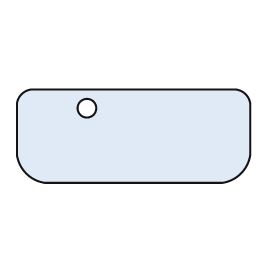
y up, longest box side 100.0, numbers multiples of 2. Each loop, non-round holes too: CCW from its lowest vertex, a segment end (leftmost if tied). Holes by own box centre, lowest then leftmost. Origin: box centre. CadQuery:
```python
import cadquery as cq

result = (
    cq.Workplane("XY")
    .moveTo(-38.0, -20.0)
    .lineTo(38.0, -20.0)
    .threePointArc((46.0, -16.0), (50.0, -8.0))
    .lineTo(50.0, 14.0)
    .threePointArc((48.0, 18.0), (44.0, 20.0))
    .lineTo(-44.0, 20.0)
    .threePointArc((-48.0, 18.0), (-50.0, 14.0))
    .lineTo(-50.0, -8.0)
    .threePointArc((-46.0, -16.0), (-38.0, -20.0))
    .close()
    .moveTo(-20.0, 12.0)
    .circle(4.0)
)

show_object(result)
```